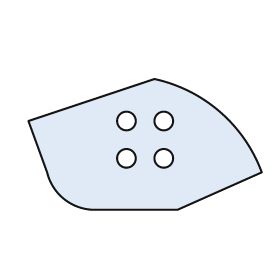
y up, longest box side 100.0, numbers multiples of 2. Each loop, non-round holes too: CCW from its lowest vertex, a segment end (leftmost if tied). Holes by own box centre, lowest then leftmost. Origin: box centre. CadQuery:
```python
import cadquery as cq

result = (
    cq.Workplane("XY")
    .moveTo(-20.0, -28.0)
    .lineTo(14.0, -28.0)
    .lineTo(50.0, -12.0)
    .threePointArc((32.0, 14.0), (4.0, 28.0))
    .lineTo(-50.0, 10.0)
    .lineTo(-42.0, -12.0)
    .threePointArc((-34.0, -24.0), (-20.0, -28.0))
    .close()
    .moveTo(-8.0, -6.0)
    .circle(4.0)
    .moveTo(8.0, -6.0)
    .circle(4.0)
    .moveTo(-8.0, 10.0)
    .circle(4.0)
    .moveTo(8.0, 10.0)
    .circle(4.0)
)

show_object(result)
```